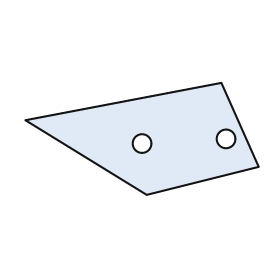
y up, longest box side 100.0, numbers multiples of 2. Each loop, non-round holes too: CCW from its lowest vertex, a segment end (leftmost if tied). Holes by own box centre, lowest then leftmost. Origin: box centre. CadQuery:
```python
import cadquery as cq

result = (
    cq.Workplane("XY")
    .moveTo(2.0, -24.0)
    .lineTo(50.0, -12.0)
    .lineTo(34.0, 24.0)
    .lineTo(-50.0, 8.0)
    .close()
    .moveTo(0.0, -2.0)
    .circle(4.0)
    .moveTo(36.0, 0.0)
    .circle(4.0)
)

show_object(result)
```